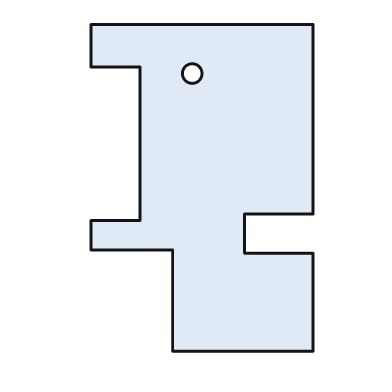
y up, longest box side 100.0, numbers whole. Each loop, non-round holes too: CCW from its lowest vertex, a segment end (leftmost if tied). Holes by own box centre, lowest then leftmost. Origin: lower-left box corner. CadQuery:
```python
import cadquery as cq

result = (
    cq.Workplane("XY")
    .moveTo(25.0, 0.0)
    .lineTo(68.0, 0.0)
    .lineTo(68.0, 30.0)
    .lineTo(47.0, 30.0)
    .lineTo(47.0, 42.0)
    .lineTo(68.0, 42.0)
    .lineTo(68.0, 100.0)
    .lineTo(0.0, 100.0)
    .lineTo(0.0, 87.0)
    .lineTo(15.0, 87.0)
    .lineTo(15.0, 40.0)
    .lineTo(0.0, 40.0)
    .lineTo(0.0, 31.0)
    .lineTo(25.0, 31.0)
    .close()
    .moveTo(31.0, 85.0)
    .circle(3.0)
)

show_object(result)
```